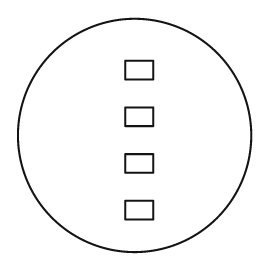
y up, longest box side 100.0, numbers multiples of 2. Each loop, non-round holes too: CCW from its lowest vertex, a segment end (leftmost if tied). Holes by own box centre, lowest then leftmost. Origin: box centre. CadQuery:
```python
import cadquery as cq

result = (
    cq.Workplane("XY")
    .moveTo(0.0, 0.0)
    .circle(50.0)
    .moveTo(-4.0, -36.0)
    .lineTo(8.0, -36.0)
    .lineTo(8.0, -28.0)
    .lineTo(-4.0, -28.0)
    .close()
    .moveTo(-4.0, -16.0)
    .lineTo(8.0, -16.0)
    .lineTo(8.0, -8.0)
    .lineTo(-4.0, -8.0)
    .close()
    .moveTo(-4.0, 4.0)
    .lineTo(8.0, 4.0)
    .lineTo(8.0, 12.0)
    .lineTo(-4.0, 12.0)
    .close()
    .moveTo(-4.0, 24.0)
    .lineTo(8.0, 24.0)
    .lineTo(8.0, 32.0)
    .lineTo(-4.0, 32.0)
    .close()
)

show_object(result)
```